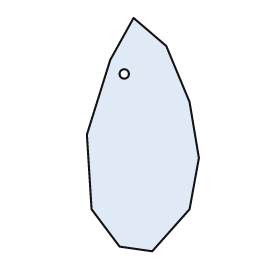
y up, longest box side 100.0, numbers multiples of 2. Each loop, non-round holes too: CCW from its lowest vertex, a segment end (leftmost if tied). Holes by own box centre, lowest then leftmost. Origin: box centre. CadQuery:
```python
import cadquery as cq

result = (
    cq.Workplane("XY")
    .moveTo(4.0, -50.0)
    .lineTo(20.0, -32.0)
    .lineTo(24.0, -10.0)
    .lineTo(20.0, 14.0)
    .lineTo(10.0, 38.0)
    .lineTo(-4.0, 50.0)
    .lineTo(-14.0, 32.0)
    .lineTo(-24.0, 0.0)
    .lineTo(-22.0, -32.0)
    .lineTo(-10.0, -48.0)
    .close()
    .moveTo(-8.0, 26.0)
    .circle(2.0)
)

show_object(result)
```